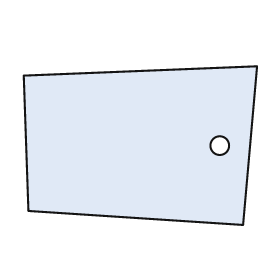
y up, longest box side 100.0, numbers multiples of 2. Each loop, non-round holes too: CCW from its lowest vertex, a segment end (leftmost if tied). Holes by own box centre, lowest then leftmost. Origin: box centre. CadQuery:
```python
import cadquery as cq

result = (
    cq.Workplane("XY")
    .moveTo(44.0, -34.0)
    .lineTo(50.0, 34.0)
    .lineTo(-50.0, 30.0)
    .lineTo(-48.0, -28.0)
    .close()
    .moveTo(34.0, 0.0)
    .circle(4.0)
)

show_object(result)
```